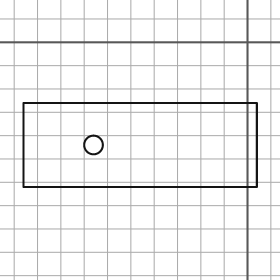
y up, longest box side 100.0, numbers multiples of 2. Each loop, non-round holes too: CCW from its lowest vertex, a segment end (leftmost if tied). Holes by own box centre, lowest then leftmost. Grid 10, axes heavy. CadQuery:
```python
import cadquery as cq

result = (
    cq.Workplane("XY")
    .moveTo(-96.0, -62.0)
    .lineTo(4.0, -62.0)
    .lineTo(4.0, -26.0)
    .lineTo(-96.0, -26.0)
    .close()
    .moveTo(-66.0, -44.0)
    .circle(4.0)
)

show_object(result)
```